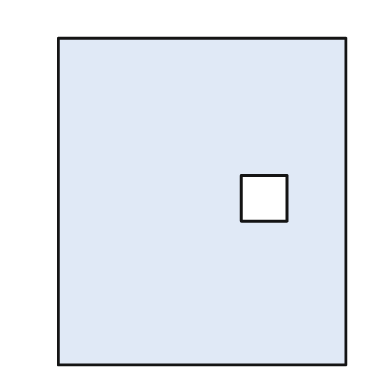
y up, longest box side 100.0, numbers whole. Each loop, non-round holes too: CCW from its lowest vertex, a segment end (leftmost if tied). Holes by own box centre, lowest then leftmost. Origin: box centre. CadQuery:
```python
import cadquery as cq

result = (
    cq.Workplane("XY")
    .moveTo(-44.0, -50.0)
    .lineTo(44.0, -50.0)
    .lineTo(44.0, 50.0)
    .lineTo(-44.0, 50.0)
    .close()
    .moveTo(12.0, -6.0)
    .lineTo(26.0, -6.0)
    .lineTo(26.0, 8.0)
    .lineTo(12.0, 8.0)
    .close()
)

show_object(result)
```